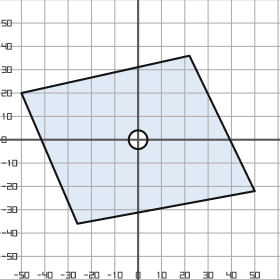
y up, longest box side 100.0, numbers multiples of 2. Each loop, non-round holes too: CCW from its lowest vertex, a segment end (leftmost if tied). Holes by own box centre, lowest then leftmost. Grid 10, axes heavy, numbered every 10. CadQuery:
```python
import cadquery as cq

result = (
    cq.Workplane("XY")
    .moveTo(-26.0, -36.0)
    .lineTo(50.0, -22.0)
    .lineTo(22.0, 36.0)
    .lineTo(-50.0, 20.0)
    .close()
    .moveTo(0.0, 0.0)
    .circle(4.0)
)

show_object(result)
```